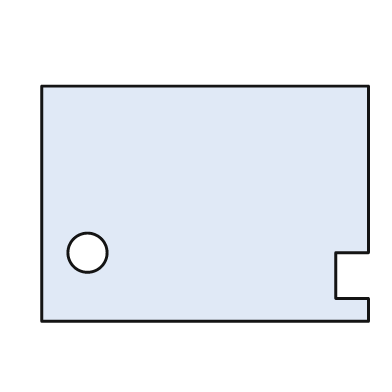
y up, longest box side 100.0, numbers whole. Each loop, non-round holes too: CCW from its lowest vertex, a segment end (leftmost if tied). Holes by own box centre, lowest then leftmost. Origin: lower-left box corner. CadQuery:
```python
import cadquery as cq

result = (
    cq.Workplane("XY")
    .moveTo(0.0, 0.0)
    .lineTo(100.0, 0.0)
    .lineTo(100.0, 7.0)
    .lineTo(90.0, 7.0)
    .lineTo(90.0, 21.0)
    .lineTo(100.0, 21.0)
    .lineTo(100.0, 72.0)
    .lineTo(0.0, 72.0)
    .close()
    .moveTo(14.0, 21.0)
    .circle(6.0)
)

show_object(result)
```